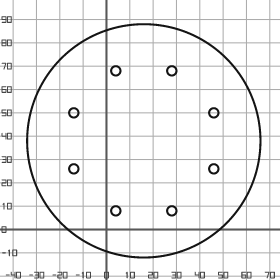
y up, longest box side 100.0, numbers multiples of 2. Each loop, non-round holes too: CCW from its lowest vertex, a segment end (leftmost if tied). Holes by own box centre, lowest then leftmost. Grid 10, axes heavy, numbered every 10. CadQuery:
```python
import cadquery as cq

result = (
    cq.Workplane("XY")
    .moveTo(16.0, 38.0)
    .circle(50.0)
    .moveTo(4.0, 8.0)
    .circle(2.0)
    .moveTo(28.0, 8.0)
    .circle(2.0)
    .moveTo(-14.0, 26.0)
    .circle(2.0)
    .moveTo(46.0, 26.0)
    .circle(2.0)
    .moveTo(-14.0, 50.0)
    .circle(2.0)
    .moveTo(46.0, 50.0)
    .circle(2.0)
    .moveTo(4.0, 68.0)
    .circle(2.0)
    .moveTo(28.0, 68.0)
    .circle(2.0)
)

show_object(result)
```